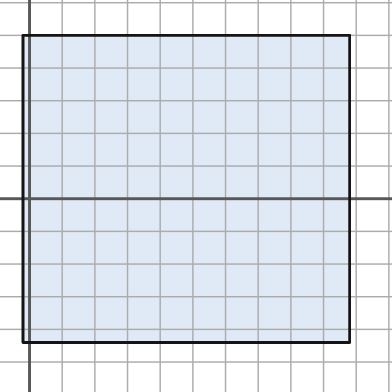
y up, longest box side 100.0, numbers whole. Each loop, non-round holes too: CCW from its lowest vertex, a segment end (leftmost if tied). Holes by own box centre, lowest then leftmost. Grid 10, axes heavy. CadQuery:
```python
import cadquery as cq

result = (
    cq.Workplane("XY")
    .moveTo(-2.0, -44.0)
    .lineTo(98.0, -44.0)
    .lineTo(98.0, 50.0)
    .lineTo(-2.0, 50.0)
    .close()
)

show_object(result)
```